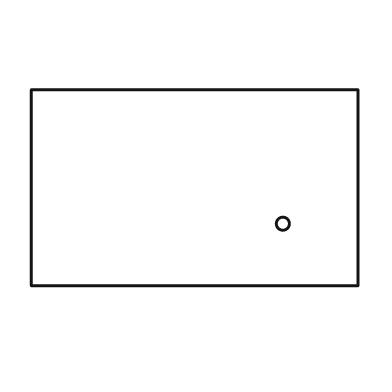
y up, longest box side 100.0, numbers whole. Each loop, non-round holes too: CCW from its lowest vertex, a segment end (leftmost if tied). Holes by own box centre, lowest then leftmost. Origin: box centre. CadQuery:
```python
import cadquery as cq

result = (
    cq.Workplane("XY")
    .moveTo(-50.0, -30.0)
    .lineTo(50.0, -30.0)
    .lineTo(50.0, 30.0)
    .lineTo(-50.0, 30.0)
    .close()
    .moveTo(27.0, -11.0)
    .circle(2.0)
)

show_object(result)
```